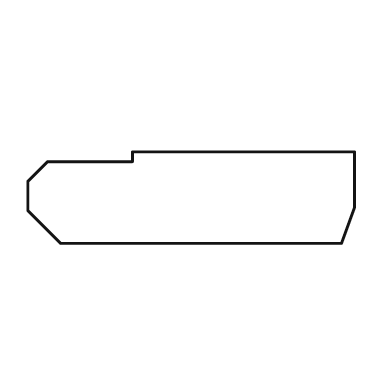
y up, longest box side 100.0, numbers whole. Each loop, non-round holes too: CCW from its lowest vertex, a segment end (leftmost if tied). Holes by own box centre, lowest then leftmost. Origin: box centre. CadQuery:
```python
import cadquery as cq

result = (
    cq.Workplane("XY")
    .moveTo(-40.0, -14.0)
    .lineTo(46.0, -14.0)
    .lineTo(50.0, -3.0)
    .lineTo(50.0, 14.0)
    .lineTo(-18.0, 14.0)
    .lineTo(-18.0, 11.0)
    .lineTo(-44.0, 11.0)
    .lineTo(-50.0, 5.0)
    .lineTo(-50.0, -4.0)
    .close()
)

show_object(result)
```